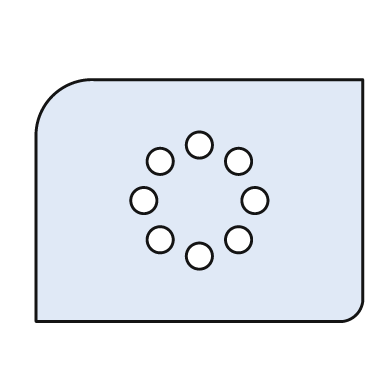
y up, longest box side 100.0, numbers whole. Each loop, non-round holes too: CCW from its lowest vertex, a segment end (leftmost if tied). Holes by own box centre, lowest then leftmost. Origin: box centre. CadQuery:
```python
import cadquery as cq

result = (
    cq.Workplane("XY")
    .moveTo(-50.0, -37.0)
    .lineTo(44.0, -37.0)
    .threePointArc((48.0, -35.0), (50.0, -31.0))
    .lineTo(50.0, 37.0)
    .lineTo(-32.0, 37.0)
    .threePointArc((-45.0, 32.0), (-50.0, 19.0))
    .close()
    .moveTo(0.0, -17.0)
    .circle(4.0)
    .moveTo(-12.0, -12.0)
    .circle(4.0)
    .moveTo(12.0, -12.0)
    .circle(4.0)
    .moveTo(-17.0, 0.0)
    .circle(4.0)
    .moveTo(17.0, 0.0)
    .circle(4.0)
    .moveTo(-12.0, 12.0)
    .circle(4.0)
    .moveTo(12.0, 12.0)
    .circle(4.0)
    .moveTo(0.0, 17.0)
    .circle(4.0)
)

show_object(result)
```